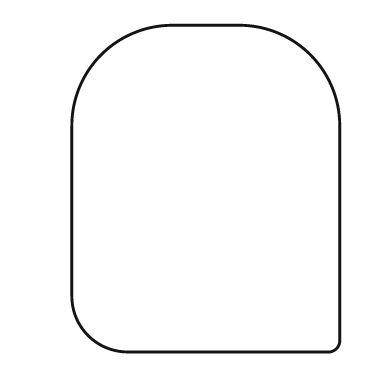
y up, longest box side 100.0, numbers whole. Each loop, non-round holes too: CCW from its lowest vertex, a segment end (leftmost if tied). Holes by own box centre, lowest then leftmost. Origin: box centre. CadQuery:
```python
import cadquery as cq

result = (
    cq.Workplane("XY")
    .moveTo(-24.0, -50.0)
    .lineTo(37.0, -50.0)
    .threePointArc((40.0, -49.0), (41.0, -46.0))
    .lineTo(41.0, 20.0)
    .threePointArc((32.0, 41.0), (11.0, 50.0))
    .lineTo(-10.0, 50.0)
    .threePointArc((-32.0, 41.0), (-41.0, 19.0))
    .lineTo(-41.0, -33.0)
    .threePointArc((-36.0, -45.0), (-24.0, -50.0))
    .close()
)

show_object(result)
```